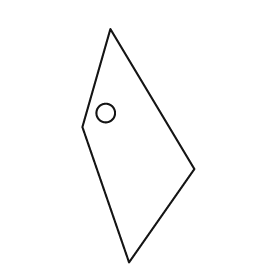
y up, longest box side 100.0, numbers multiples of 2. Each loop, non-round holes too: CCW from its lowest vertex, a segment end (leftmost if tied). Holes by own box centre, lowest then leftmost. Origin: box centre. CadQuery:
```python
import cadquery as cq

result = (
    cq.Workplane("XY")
    .moveTo(-4.0, -50.0)
    .lineTo(24.0, -10.0)
    .lineTo(-12.0, 50.0)
    .lineTo(-24.0, 8.0)
    .close()
    .moveTo(-14.0, 14.0)
    .circle(4.0)
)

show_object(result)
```